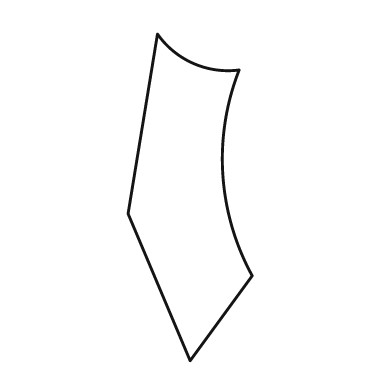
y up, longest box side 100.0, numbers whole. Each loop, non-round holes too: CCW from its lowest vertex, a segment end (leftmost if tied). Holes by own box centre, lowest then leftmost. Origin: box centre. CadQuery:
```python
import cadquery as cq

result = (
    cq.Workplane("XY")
    .moveTo(0.0, -50.0)
    .lineTo(19.0, -24.0)
    .threePointArc((10.0, 7.0), (15.0, 39.0))
    .threePointArc((1.0, 41.0), (-10.0, 50.0))
    .lineTo(-19.0, -5.0)
    .close()
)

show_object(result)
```